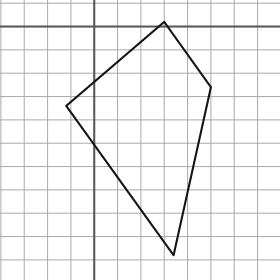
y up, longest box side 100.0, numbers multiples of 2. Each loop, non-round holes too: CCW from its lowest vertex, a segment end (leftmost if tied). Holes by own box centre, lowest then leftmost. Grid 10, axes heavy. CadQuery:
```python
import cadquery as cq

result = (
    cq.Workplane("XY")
    .moveTo(34.0, -98.0)
    .lineTo(50.0, -26.0)
    .lineTo(30.0, 2.0)
    .lineTo(-12.0, -34.0)
    .close()
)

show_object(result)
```